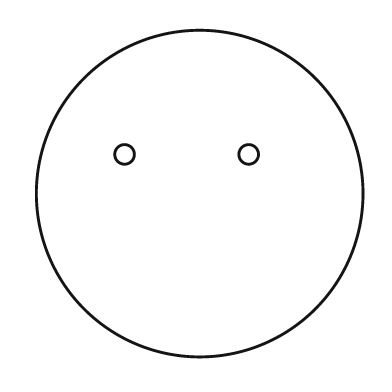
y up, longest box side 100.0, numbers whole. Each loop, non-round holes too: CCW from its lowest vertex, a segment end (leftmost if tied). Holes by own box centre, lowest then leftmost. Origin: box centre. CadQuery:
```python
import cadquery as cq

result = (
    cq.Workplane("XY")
    .moveTo(0.0, 0.0)
    .circle(50.0)
    .moveTo(-23.0, 12.0)
    .circle(3.0)
    .moveTo(15.0, 12.0)
    .circle(3.0)
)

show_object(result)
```